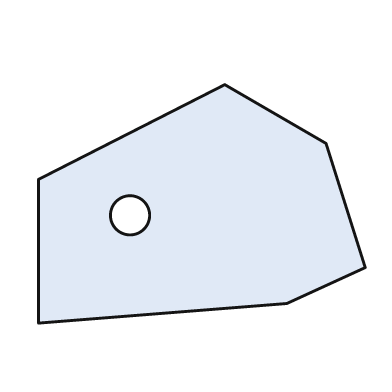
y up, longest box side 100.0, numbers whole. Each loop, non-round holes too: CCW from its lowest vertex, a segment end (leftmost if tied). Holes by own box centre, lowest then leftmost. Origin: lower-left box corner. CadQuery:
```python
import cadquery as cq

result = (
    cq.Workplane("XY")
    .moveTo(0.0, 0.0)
    .lineTo(76.0, 6.0)
    .lineTo(100.0, 17.0)
    .lineTo(88.0, 55.0)
    .lineTo(57.0, 73.0)
    .lineTo(0.0, 44.0)
    .close()
    .moveTo(28.0, 33.0)
    .circle(6.0)
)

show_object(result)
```